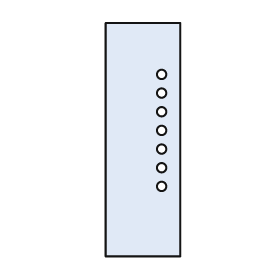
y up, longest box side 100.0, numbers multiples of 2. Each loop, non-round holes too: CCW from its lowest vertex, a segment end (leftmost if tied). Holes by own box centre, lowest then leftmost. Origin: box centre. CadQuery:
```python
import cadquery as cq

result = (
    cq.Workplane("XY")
    .moveTo(-16.0, -50.0)
    .lineTo(16.0, -50.0)
    .lineTo(16.0, 50.0)
    .lineTo(-16.0, 50.0)
    .close()
    .moveTo(8.0, -20.0)
    .circle(2.0)
    .moveTo(8.0, -12.0)
    .circle(2.0)
    .moveTo(8.0, -4.0)
    .circle(2.0)
    .moveTo(8.0, 4.0)
    .circle(2.0)
    .moveTo(8.0, 12.0)
    .circle(2.0)
    .moveTo(8.0, 20.0)
    .circle(2.0)
    .moveTo(8.0, 28.0)
    .circle(2.0)
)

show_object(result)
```